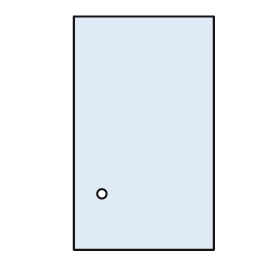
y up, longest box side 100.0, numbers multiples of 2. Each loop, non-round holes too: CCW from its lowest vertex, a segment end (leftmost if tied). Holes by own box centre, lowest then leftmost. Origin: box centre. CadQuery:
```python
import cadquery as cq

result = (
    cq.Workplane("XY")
    .moveTo(-30.0, -50.0)
    .lineTo(30.0, -50.0)
    .lineTo(30.0, 50.0)
    .lineTo(-30.0, 50.0)
    .close()
    .moveTo(-18.0, -26.0)
    .circle(2.0)
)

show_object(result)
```